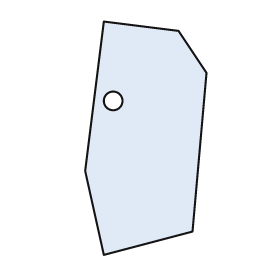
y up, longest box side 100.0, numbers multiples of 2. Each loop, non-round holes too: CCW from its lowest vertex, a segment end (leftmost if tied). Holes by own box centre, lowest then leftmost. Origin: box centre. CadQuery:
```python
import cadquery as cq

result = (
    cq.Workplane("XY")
    .moveTo(-18.0, -50.0)
    .lineTo(20.0, -40.0)
    .lineTo(26.0, 28.0)
    .lineTo(14.0, 46.0)
    .lineTo(-18.0, 50.0)
    .lineTo(-26.0, -14.0)
    .close()
    .moveTo(-14.0, 16.0)
    .circle(4.0)
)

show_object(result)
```